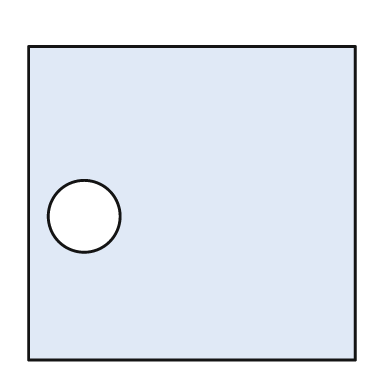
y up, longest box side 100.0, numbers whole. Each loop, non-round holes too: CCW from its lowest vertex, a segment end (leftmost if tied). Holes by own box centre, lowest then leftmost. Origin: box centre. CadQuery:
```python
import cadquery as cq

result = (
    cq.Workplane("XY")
    .moveTo(-50.0, -48.0)
    .lineTo(50.0, -48.0)
    .lineTo(50.0, 48.0)
    .lineTo(-50.0, 48.0)
    .close()
    .moveTo(-33.0, -4.0)
    .circle(11.0)
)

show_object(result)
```